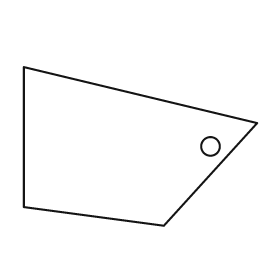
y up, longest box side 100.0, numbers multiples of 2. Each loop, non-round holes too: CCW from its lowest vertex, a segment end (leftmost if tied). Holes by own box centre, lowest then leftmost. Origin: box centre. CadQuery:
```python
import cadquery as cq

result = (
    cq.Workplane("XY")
    .moveTo(10.0, -34.0)
    .lineTo(50.0, 10.0)
    .lineTo(-50.0, 34.0)
    .lineTo(-50.0, -26.0)
    .close()
    .moveTo(30.0, 0.0)
    .circle(4.0)
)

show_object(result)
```